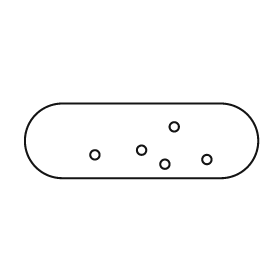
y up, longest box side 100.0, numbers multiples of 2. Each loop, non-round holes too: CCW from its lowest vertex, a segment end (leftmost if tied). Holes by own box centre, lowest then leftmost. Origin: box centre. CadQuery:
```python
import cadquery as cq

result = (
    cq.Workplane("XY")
    .moveTo(-34.0, -16.0)
    .lineTo(34.0, -16.0)
    .threePointArc((50.0, 0.0), (34.0, 16.0))
    .lineTo(-34.0, 16.0)
    .threePointArc((-50.0, 0.0), (-34.0, -16.0))
    .close()
    .moveTo(10.0, -10.0)
    .circle(2.0)
    .moveTo(28.0, -8.0)
    .circle(2.0)
    .moveTo(-20.0, -6.0)
    .circle(2.0)
    .moveTo(0.0, -4.0)
    .circle(2.0)
    .moveTo(14.0, 6.0)
    .circle(2.0)
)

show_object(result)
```